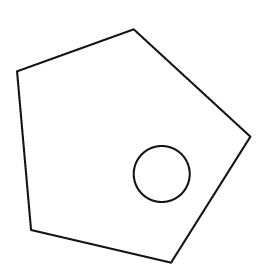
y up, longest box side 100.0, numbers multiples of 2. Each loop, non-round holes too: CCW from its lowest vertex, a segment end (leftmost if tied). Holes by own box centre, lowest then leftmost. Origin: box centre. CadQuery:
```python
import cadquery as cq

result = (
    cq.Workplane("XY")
    .moveTo(16.0, -50.0)
    .lineTo(50.0, 4.0)
    .lineTo(0.0, 50.0)
    .lineTo(-50.0, 32.0)
    .lineTo(-44.0, -36.0)
    .close()
    .moveTo(12.0, -12.0)
    .circle(12.0)
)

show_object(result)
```